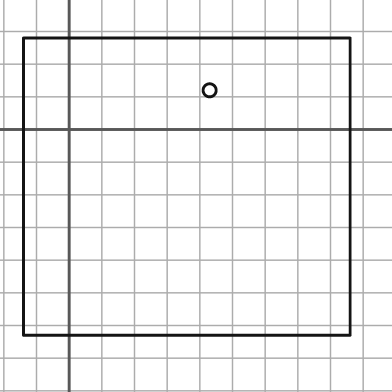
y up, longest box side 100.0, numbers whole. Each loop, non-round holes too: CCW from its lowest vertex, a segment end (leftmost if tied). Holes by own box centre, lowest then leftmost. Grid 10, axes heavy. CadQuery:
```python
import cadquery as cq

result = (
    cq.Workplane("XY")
    .moveTo(-14.0, -63.0)
    .lineTo(86.0, -63.0)
    .lineTo(86.0, 28.0)
    .lineTo(-14.0, 28.0)
    .close()
    .moveTo(43.0, 12.0)
    .circle(2.0)
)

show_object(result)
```